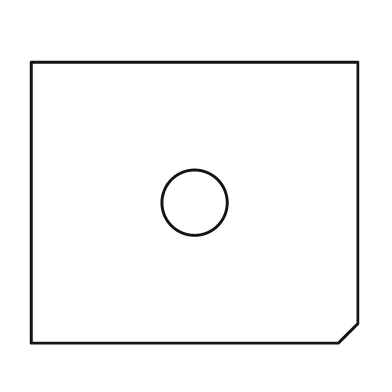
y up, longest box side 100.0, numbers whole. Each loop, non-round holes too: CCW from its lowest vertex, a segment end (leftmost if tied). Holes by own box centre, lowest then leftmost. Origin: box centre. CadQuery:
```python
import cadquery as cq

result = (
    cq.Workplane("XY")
    .moveTo(-50.0, -43.0)
    .lineTo(44.0, -43.0)
    .lineTo(50.0, -37.0)
    .lineTo(50.0, 43.0)
    .lineTo(-50.0, 43.0)
    .close()
    .moveTo(0.0, 0.0)
    .circle(10.0)
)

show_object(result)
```